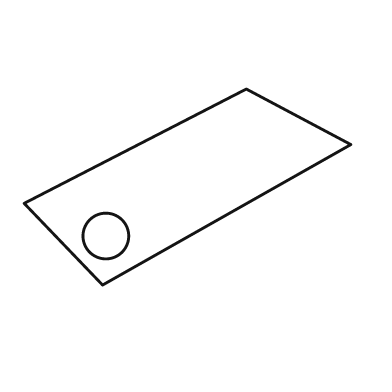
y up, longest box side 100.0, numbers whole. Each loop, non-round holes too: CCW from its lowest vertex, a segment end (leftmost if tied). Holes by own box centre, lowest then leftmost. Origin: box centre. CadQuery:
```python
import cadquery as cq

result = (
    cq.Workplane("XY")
    .moveTo(-26.0, -30.0)
    .lineTo(50.0, 13.0)
    .lineTo(18.0, 30.0)
    .lineTo(-50.0, -5.0)
    .close()
    .moveTo(-25.0, -15.0)
    .circle(7.0)
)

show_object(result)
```